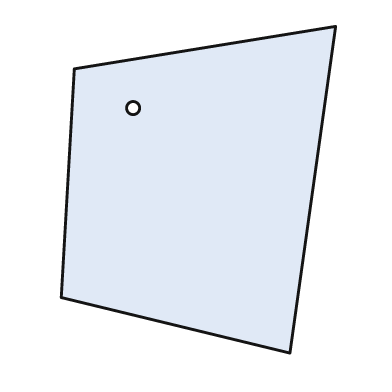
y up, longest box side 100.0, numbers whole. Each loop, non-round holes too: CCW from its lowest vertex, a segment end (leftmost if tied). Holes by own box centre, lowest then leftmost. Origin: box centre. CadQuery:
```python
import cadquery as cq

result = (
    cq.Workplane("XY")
    .moveTo(28.0, -50.0)
    .lineTo(42.0, 50.0)
    .lineTo(-38.0, 37.0)
    .lineTo(-42.0, -33.0)
    .close()
    .moveTo(-20.0, 25.0)
    .circle(2.0)
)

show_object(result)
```